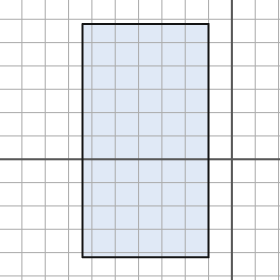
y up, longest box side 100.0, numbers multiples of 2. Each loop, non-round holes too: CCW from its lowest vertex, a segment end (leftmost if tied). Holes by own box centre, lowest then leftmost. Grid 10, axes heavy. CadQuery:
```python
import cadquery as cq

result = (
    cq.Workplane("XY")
    .moveTo(-64.0, -42.0)
    .lineTo(-10.0, -42.0)
    .lineTo(-10.0, 58.0)
    .lineTo(-64.0, 58.0)
    .close()
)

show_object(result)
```